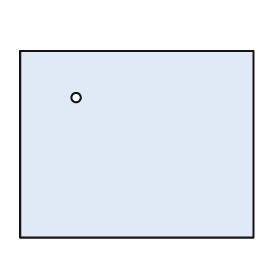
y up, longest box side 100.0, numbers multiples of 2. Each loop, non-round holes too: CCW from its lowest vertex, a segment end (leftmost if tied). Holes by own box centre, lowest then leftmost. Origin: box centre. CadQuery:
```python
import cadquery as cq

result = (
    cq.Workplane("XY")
    .moveTo(-50.0, -40.0)
    .lineTo(50.0, -40.0)
    .lineTo(50.0, 40.0)
    .lineTo(-50.0, 40.0)
    .close()
    .moveTo(-26.0, 20.0)
    .circle(2.0)
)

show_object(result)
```